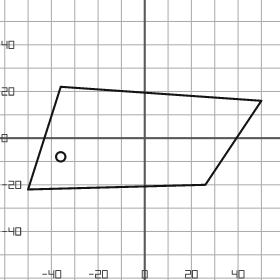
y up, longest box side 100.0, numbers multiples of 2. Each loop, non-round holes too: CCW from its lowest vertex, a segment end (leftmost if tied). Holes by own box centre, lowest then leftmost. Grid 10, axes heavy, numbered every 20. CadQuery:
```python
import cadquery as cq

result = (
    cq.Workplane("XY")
    .moveTo(-50.0, -22.0)
    .lineTo(26.0, -20.0)
    .lineTo(50.0, 16.0)
    .lineTo(-36.0, 22.0)
    .close()
    .moveTo(-36.0, -8.0)
    .circle(2.0)
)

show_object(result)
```